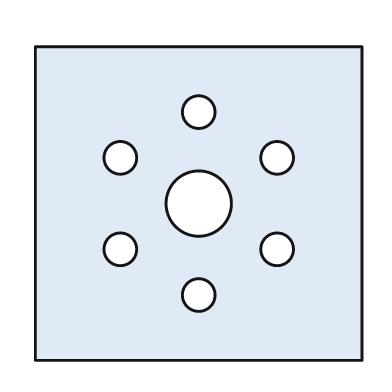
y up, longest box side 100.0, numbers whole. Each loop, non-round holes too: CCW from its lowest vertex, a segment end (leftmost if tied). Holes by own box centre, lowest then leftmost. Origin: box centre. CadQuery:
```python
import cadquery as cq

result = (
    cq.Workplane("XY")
    .moveTo(-50.0, -48.0)
    .lineTo(50.0, -48.0)
    .lineTo(50.0, 48.0)
    .lineTo(-50.0, 48.0)
    .close()
    .moveTo(0.0, -28.0)
    .circle(5.0)
    .moveTo(-24.0, -14.0)
    .circle(5.0)
    .moveTo(24.0, -14.0)
    .circle(5.0)
    .moveTo(0.0, 0.0)
    .circle(10.0)
    .moveTo(-24.0, 14.0)
    .circle(5.0)
    .moveTo(24.0, 14.0)
    .circle(5.0)
    .moveTo(0.0, 28.0)
    .circle(5.0)
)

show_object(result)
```